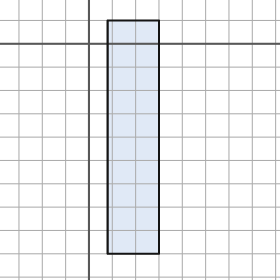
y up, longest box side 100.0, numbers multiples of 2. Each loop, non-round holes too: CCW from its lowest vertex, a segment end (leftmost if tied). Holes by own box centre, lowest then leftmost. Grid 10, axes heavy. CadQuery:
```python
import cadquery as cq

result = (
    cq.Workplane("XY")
    .moveTo(8.0, -90.0)
    .lineTo(30.0, -90.0)
    .lineTo(30.0, 10.0)
    .lineTo(8.0, 10.0)
    .close()
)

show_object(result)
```